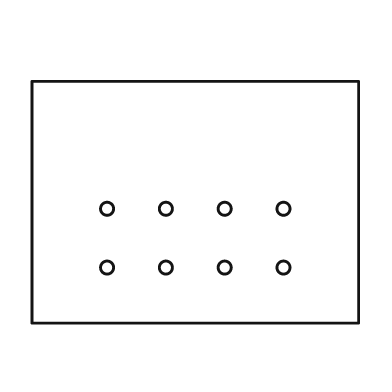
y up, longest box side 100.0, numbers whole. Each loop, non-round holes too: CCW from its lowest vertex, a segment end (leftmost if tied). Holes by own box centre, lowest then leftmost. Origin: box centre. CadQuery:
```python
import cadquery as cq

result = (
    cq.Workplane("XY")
    .moveTo(-50.0, -37.0)
    .lineTo(50.0, -37.0)
    .lineTo(50.0, 37.0)
    .lineTo(-50.0, 37.0)
    .close()
    .moveTo(-27.0, -20.0)
    .circle(2.0)
    .moveTo(-9.0, -20.0)
    .circle(2.0)
    .moveTo(9.0, -20.0)
    .circle(2.0)
    .moveTo(27.0, -20.0)
    .circle(2.0)
    .moveTo(-27.0, -2.0)
    .circle(2.0)
    .moveTo(-9.0, -2.0)
    .circle(2.0)
    .moveTo(9.0, -2.0)
    .circle(2.0)
    .moveTo(27.0, -2.0)
    .circle(2.0)
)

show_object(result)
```